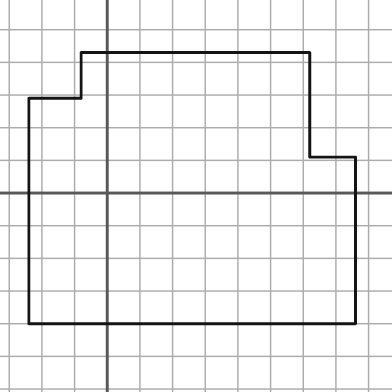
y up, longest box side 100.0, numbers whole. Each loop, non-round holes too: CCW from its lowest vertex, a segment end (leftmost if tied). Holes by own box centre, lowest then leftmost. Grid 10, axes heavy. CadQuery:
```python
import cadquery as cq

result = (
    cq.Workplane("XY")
    .moveTo(-24.0, -40.0)
    .lineTo(76.0, -40.0)
    .lineTo(76.0, 11.0)
    .lineTo(62.0, 11.0)
    .lineTo(62.0, 43.0)
    .lineTo(-8.0, 43.0)
    .lineTo(-8.0, 29.0)
    .lineTo(-24.0, 29.0)
    .close()
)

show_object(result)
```